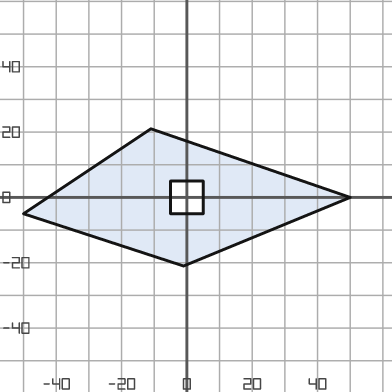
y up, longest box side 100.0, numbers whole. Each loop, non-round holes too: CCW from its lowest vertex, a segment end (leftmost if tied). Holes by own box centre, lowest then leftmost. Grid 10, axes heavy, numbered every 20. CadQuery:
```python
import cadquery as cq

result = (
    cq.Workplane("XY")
    .moveTo(-1.0, -21.0)
    .lineTo(50.0, 0.0)
    .lineTo(-11.0, 21.0)
    .lineTo(-50.0, -5.0)
    .close()
    .moveTo(-5.0, -5.0)
    .lineTo(5.0, -5.0)
    .lineTo(5.0, 5.0)
    .lineTo(-5.0, 5.0)
    .close()
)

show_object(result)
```